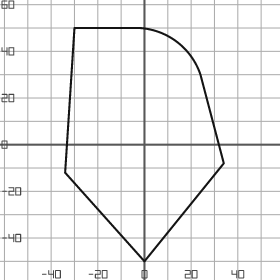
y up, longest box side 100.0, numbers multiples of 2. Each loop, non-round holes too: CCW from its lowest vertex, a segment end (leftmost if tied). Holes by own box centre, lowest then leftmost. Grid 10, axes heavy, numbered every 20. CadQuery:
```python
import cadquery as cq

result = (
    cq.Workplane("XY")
    .moveTo(0.0, -50.0)
    .lineTo(34.0, -8.0)
    .lineTo(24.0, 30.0)
    .threePointArc((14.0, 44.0), (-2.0, 50.0))
    .lineTo(-30.0, 50.0)
    .lineTo(-34.0, -12.0)
    .close()
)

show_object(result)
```